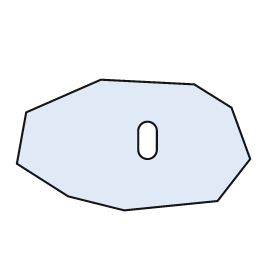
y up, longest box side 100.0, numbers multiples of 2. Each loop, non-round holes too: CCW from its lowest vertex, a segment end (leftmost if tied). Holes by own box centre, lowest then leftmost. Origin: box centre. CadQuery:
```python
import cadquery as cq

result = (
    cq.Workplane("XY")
    .moveTo(-4.0, -28.0)
    .lineTo(36.0, -24.0)
    .lineTo(50.0, -6.0)
    .lineTo(42.0, 16.0)
    .lineTo(26.0, 26.0)
    .lineTo(-14.0, 28.0)
    .lineTo(-46.0, 14.0)
    .lineTo(-50.0, -8.0)
    .lineTo(-28.0, -22.0)
    .close()
    .moveTo(2.0, -2.0)
    .threePointArc((6.0, -6.0), (10.0, -2.0))
    .lineTo(10.0, 6.0)
    .threePointArc((6.0, 10.0), (2.0, 6.0))
    .close()
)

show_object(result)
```